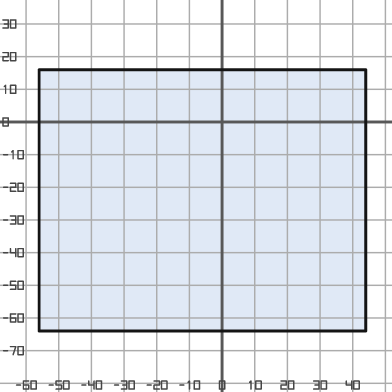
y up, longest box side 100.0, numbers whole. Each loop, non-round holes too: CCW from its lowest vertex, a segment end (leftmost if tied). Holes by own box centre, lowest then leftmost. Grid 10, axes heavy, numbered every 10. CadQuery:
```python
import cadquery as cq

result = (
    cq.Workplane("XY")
    .moveTo(-56.0, -64.0)
    .lineTo(44.0, -64.0)
    .lineTo(44.0, 16.0)
    .lineTo(-56.0, 16.0)
    .close()
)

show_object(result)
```